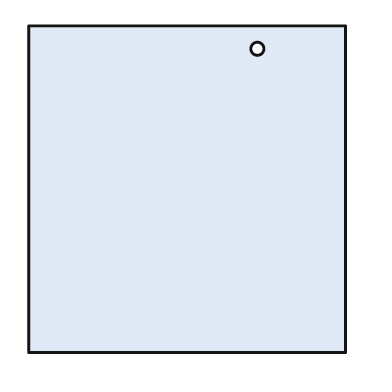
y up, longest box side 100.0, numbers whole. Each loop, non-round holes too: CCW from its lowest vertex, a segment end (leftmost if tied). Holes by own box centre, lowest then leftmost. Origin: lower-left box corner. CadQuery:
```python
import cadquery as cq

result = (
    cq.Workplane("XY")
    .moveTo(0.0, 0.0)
    .lineTo(97.0, 0.0)
    .lineTo(97.0, 100.0)
    .lineTo(0.0, 100.0)
    .close()
    .moveTo(70.0, 93.0)
    .circle(2.0)
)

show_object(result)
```